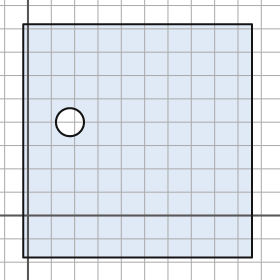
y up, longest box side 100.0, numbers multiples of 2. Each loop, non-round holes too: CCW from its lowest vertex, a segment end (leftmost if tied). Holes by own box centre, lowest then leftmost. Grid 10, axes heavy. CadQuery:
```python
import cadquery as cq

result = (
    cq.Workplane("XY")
    .moveTo(-2.0, -18.0)
    .lineTo(96.0, -18.0)
    .lineTo(96.0, 82.0)
    .lineTo(-2.0, 82.0)
    .close()
    .moveTo(18.0, 40.0)
    .circle(6.0)
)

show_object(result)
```